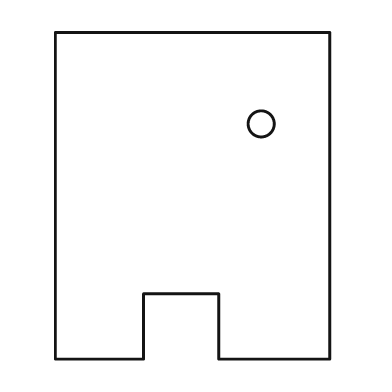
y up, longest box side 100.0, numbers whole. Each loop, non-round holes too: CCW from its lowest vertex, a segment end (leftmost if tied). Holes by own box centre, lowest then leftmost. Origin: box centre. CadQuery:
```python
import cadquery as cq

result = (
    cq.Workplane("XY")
    .moveTo(-42.0, -50.0)
    .lineTo(-15.0, -50.0)
    .lineTo(-15.0, -30.0)
    .lineTo(8.0, -30.0)
    .lineTo(8.0, -50.0)
    .lineTo(42.0, -50.0)
    .lineTo(42.0, 50.0)
    .lineTo(-42.0, 50.0)
    .close()
    .moveTo(21.0, 22.0)
    .circle(4.0)
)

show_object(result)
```